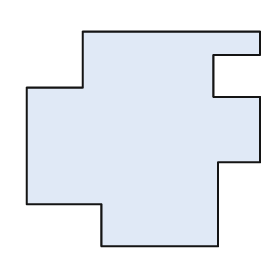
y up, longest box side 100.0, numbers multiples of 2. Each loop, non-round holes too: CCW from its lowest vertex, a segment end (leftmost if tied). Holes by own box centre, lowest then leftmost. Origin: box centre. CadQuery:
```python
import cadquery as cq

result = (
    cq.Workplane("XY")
    .moveTo(-18.0, -46.0)
    .lineTo(32.0, -46.0)
    .lineTo(32.0, -10.0)
    .lineTo(50.0, -10.0)
    .lineTo(50.0, 18.0)
    .lineTo(30.0, 18.0)
    .lineTo(30.0, 36.0)
    .lineTo(50.0, 36.0)
    .lineTo(50.0, 46.0)
    .lineTo(-26.0, 46.0)
    .lineTo(-26.0, 22.0)
    .lineTo(-50.0, 22.0)
    .lineTo(-50.0, -28.0)
    .lineTo(-18.0, -28.0)
    .close()
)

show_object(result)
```